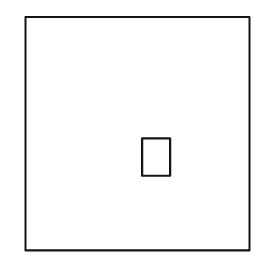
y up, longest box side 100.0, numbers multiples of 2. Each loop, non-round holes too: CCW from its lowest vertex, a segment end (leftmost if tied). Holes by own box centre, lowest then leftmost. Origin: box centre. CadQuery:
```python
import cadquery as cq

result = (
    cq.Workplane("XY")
    .moveTo(-48.0, -50.0)
    .lineTo(48.0, -50.0)
    .lineTo(48.0, 50.0)
    .lineTo(-48.0, 50.0)
    .close()
    .moveTo(2.0, -18.0)
    .lineTo(14.0, -18.0)
    .lineTo(14.0, -2.0)
    .lineTo(2.0, -2.0)
    .close()
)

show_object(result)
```